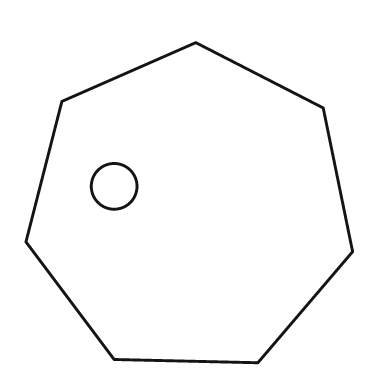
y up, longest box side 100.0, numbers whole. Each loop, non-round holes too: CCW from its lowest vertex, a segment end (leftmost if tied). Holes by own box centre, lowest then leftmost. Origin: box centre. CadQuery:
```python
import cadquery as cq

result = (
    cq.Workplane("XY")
    .moveTo(21.0, -49.0)
    .lineTo(50.0, -15.0)
    .lineTo(41.0, 29.0)
    .lineTo(2.0, 49.0)
    .lineTo(-39.0, 31.0)
    .lineTo(-50.0, -12.0)
    .lineTo(-23.0, -48.0)
    .close()
    .moveTo(-23.0, 5.0)
    .circle(7.0)
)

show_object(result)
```